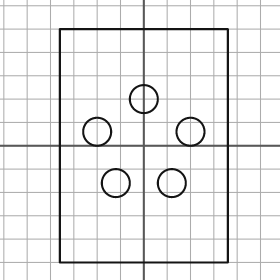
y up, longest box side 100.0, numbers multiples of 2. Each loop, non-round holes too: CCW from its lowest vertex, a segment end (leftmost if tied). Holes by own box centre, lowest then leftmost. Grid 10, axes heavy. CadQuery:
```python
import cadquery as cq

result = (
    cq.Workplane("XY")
    .moveTo(-36.0, -50.0)
    .lineTo(36.0, -50.0)
    .lineTo(36.0, 50.0)
    .lineTo(-36.0, 50.0)
    .close()
    .moveTo(-12.0, -16.0)
    .circle(6.0)
    .moveTo(12.0, -16.0)
    .circle(6.0)
    .moveTo(-20.0, 6.0)
    .circle(6.0)
    .moveTo(20.0, 6.0)
    .circle(6.0)
    .moveTo(0.0, 20.0)
    .circle(6.0)
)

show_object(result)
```